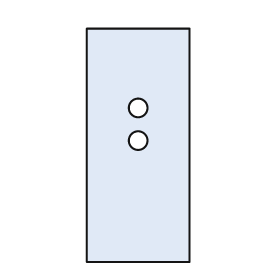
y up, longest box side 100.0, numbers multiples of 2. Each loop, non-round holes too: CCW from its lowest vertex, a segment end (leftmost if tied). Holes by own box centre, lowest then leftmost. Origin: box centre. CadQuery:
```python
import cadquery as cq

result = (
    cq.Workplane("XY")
    .moveTo(-22.0, -50.0)
    .lineTo(22.0, -50.0)
    .lineTo(22.0, 50.0)
    .lineTo(-22.0, 50.0)
    .close()
    .moveTo(0.0, 2.0)
    .circle(4.0)
    .moveTo(0.0, 16.0)
    .circle(4.0)
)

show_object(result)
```